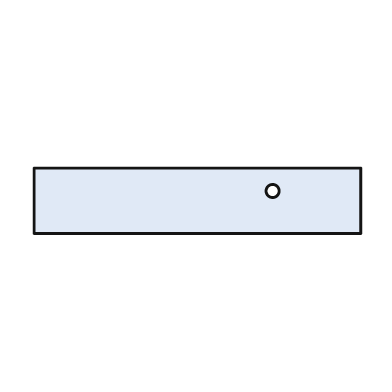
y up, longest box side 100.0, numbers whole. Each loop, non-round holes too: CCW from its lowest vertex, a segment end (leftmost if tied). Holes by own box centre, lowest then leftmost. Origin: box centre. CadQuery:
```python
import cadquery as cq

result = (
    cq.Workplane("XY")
    .moveTo(-50.0, -10.0)
    .lineTo(50.0, -10.0)
    .lineTo(50.0, 10.0)
    .lineTo(-50.0, 10.0)
    .close()
    .moveTo(23.0, 3.0)
    .circle(2.0)
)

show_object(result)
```